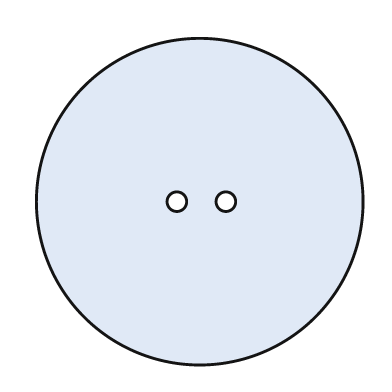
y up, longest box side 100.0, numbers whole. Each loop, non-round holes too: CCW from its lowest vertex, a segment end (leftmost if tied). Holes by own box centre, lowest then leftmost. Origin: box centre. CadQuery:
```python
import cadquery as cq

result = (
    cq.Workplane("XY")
    .moveTo(0.0, 0.0)
    .circle(50.0)
    .moveTo(-7.0, 0.0)
    .circle(3.0)
    .moveTo(8.0, 0.0)
    .circle(3.0)
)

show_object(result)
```